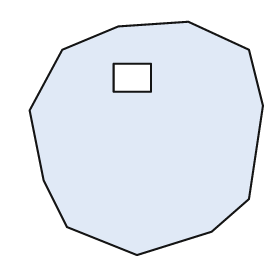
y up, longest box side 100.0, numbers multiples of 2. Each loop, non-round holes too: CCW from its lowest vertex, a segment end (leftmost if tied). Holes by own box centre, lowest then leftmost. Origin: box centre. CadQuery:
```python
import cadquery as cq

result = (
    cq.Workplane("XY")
    .moveTo(-4.0, -50.0)
    .lineTo(28.0, -40.0)
    .lineTo(44.0, -26.0)
    .lineTo(50.0, 14.0)
    .lineTo(44.0, 38.0)
    .lineTo(18.0, 50.0)
    .lineTo(-12.0, 48.0)
    .lineTo(-36.0, 38.0)
    .lineTo(-50.0, 12.0)
    .lineTo(-44.0, -18.0)
    .lineTo(-34.0, -38.0)
    .close()
    .moveTo(-14.0, 20.0)
    .lineTo(2.0, 20.0)
    .lineTo(2.0, 32.0)
    .lineTo(-14.0, 32.0)
    .close()
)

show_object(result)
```